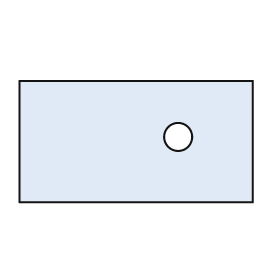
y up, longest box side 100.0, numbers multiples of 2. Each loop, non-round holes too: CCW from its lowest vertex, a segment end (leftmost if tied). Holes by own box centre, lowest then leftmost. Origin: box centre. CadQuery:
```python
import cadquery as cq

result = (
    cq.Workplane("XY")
    .moveTo(-50.0, -26.0)
    .lineTo(50.0, -26.0)
    .lineTo(50.0, 26.0)
    .lineTo(-50.0, 26.0)
    .close()
    .moveTo(18.0, 2.0)
    .circle(6.0)
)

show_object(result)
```